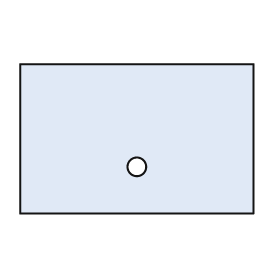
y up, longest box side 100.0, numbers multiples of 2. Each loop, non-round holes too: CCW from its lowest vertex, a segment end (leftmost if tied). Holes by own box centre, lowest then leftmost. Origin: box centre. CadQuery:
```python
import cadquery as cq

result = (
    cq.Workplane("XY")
    .moveTo(-50.0, -32.0)
    .lineTo(50.0, -32.0)
    .lineTo(50.0, 32.0)
    .lineTo(-50.0, 32.0)
    .close()
    .moveTo(0.0, -12.0)
    .circle(4.0)
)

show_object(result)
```